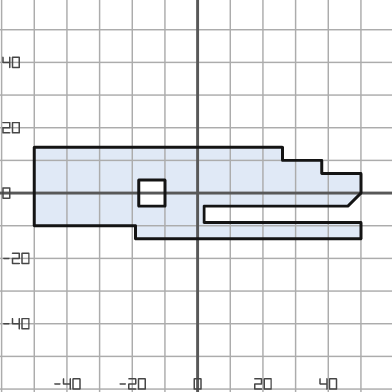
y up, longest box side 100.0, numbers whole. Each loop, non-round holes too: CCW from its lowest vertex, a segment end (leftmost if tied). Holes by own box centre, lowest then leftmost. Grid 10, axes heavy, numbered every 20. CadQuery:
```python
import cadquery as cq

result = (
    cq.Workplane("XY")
    .moveTo(-19.0, -14.0)
    .lineTo(50.0, -14.0)
    .lineTo(50.0, -9.0)
    .lineTo(2.0, -9.0)
    .lineTo(2.0, -4.0)
    .lineTo(46.0, -4.0)
    .lineTo(50.0, 0.0)
    .lineTo(50.0, 6.0)
    .lineTo(38.0, 6.0)
    .lineTo(38.0, 10.0)
    .lineTo(26.0, 10.0)
    .lineTo(26.0, 14.0)
    .lineTo(-50.0, 14.0)
    .lineTo(-50.0, -10.0)
    .lineTo(-19.0, -10.0)
    .close()
    .moveTo(-18.0, -4.0)
    .lineTo(-10.0, -4.0)
    .lineTo(-10.0, 4.0)
    .lineTo(-18.0, 4.0)
    .close()
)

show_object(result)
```